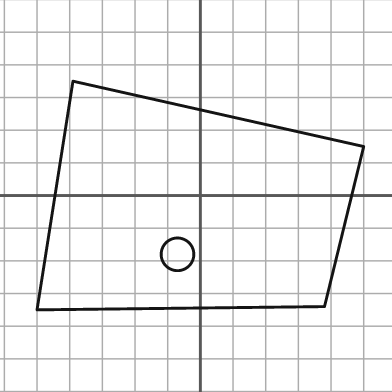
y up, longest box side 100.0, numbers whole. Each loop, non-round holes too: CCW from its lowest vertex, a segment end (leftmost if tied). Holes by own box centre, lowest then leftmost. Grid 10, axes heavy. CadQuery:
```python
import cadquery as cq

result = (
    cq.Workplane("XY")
    .moveTo(-50.0, -35.0)
    .lineTo(38.0, -34.0)
    .lineTo(50.0, 15.0)
    .lineTo(-39.0, 35.0)
    .close()
    .moveTo(-7.0, -18.0)
    .circle(5.0)
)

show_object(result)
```